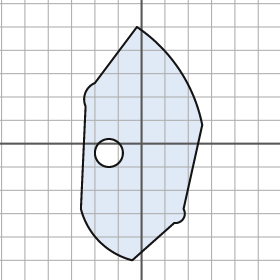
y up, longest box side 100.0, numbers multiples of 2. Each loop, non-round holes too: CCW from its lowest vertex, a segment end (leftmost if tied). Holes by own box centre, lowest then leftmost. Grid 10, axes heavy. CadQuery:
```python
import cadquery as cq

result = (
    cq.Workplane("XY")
    .moveTo(-4.0, -50.0)
    .lineTo(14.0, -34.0)
    .threePointArc((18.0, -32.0), (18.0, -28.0))
    .lineTo(26.0, 8.0)
    .threePointArc((16.0, 32.0), (-2.0, 50.0))
    .lineTo(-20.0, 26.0)
    .threePointArc((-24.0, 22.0), (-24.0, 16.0))
    .lineTo(-26.0, -28.0)
    .threePointArc((-18.0, -42.0), (-4.0, -50.0))
    .close()
    .moveTo(-14.0, -4.0)
    .circle(6.0)
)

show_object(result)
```